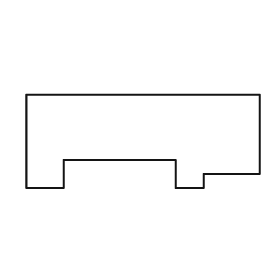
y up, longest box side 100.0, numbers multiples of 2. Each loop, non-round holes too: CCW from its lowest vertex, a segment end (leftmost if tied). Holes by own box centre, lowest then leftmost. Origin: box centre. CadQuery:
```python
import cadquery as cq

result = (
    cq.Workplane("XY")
    .moveTo(-50.0, -20.0)
    .lineTo(-34.0, -20.0)
    .lineTo(-34.0, -8.0)
    .lineTo(14.0, -8.0)
    .lineTo(14.0, -20.0)
    .lineTo(26.0, -20.0)
    .lineTo(26.0, -14.0)
    .lineTo(50.0, -14.0)
    .lineTo(50.0, 20.0)
    .lineTo(-50.0, 20.0)
    .close()
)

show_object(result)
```